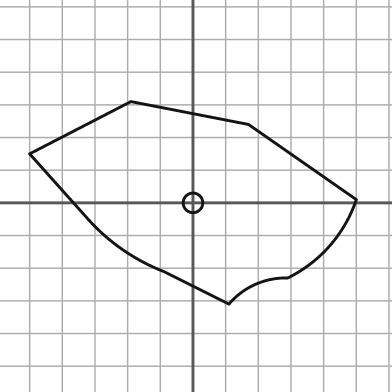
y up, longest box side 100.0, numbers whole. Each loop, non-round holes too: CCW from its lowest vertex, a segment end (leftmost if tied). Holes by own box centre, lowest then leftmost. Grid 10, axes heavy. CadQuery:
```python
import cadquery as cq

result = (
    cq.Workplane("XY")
    .moveTo(11.0, -31.0)
    .threePointArc((19.0, -25.0), (29.0, -23.0))
    .threePointArc((42.0, -13.0), (50.0, 1.0))
    .lineTo(17.0, 24.0)
    .lineTo(-19.0, 31.0)
    .lineTo(-50.0, 15.0)
    .lineTo(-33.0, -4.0)
    .threePointArc((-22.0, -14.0), (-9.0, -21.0))
    .close()
    .moveTo(0.0, 0.0)
    .circle(3.0)
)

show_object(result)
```